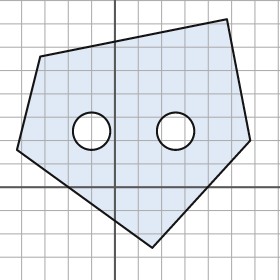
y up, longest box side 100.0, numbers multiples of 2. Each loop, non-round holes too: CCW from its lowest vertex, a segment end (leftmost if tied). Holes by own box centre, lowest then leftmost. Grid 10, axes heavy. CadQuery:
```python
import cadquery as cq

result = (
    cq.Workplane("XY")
    .moveTo(16.0, -26.0)
    .lineTo(58.0, 20.0)
    .lineTo(48.0, 72.0)
    .lineTo(-32.0, 56.0)
    .lineTo(-42.0, 16.0)
    .close()
    .moveTo(-10.0, 24.0)
    .circle(8.0)
    .moveTo(26.0, 24.0)
    .circle(8.0)
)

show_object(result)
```